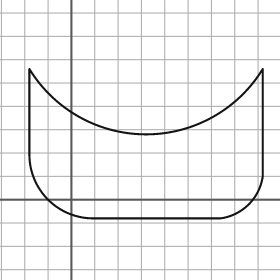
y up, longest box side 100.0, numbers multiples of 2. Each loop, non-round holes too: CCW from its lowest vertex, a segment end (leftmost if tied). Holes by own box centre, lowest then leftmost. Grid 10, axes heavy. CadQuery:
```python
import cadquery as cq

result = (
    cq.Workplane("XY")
    .moveTo(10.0, -8.0)
    .lineTo(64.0, -8.0)
    .threePointArc((76.0, -2.0), (82.0, 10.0))
    .lineTo(82.0, 56.0)
    .threePointArc((32.0, 28.0), (-18.0, 56.0))
    .lineTo(-18.0, 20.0)
    .threePointArc((-10.0, 0.0), (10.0, -8.0))
    .close()
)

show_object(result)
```